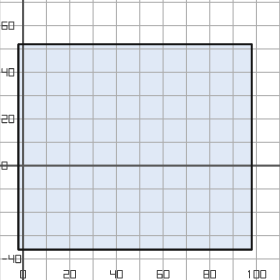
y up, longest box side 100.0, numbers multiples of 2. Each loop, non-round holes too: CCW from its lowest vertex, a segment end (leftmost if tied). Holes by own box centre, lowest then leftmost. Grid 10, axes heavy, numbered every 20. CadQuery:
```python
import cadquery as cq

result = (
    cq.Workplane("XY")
    .moveTo(-2.0, -36.0)
    .lineTo(98.0, -36.0)
    .lineTo(98.0, 52.0)
    .lineTo(-2.0, 52.0)
    .close()
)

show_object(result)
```